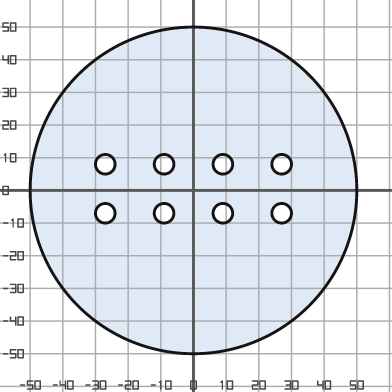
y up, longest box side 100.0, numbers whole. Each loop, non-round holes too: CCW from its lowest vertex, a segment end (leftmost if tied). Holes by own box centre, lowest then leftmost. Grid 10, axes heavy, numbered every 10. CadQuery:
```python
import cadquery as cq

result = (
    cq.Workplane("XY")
    .moveTo(0.0, 0.0)
    .circle(50.0)
    .moveTo(-27.0, -7.0)
    .circle(3.0)
    .moveTo(-9.0, -7.0)
    .circle(3.0)
    .moveTo(9.0, -7.0)
    .circle(3.0)
    .moveTo(27.0, -7.0)
    .circle(3.0)
    .moveTo(-27.0, 8.0)
    .circle(3.0)
    .moveTo(-9.0, 8.0)
    .circle(3.0)
    .moveTo(9.0, 8.0)
    .circle(3.0)
    .moveTo(27.0, 8.0)
    .circle(3.0)
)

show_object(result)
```